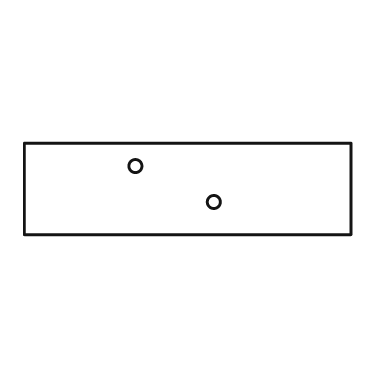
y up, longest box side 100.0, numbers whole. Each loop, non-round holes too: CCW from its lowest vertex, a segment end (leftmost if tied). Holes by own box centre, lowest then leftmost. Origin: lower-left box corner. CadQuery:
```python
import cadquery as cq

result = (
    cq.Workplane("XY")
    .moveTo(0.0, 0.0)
    .lineTo(100.0, 0.0)
    .lineTo(100.0, 28.0)
    .lineTo(0.0, 28.0)
    .close()
    .moveTo(58.0, 10.0)
    .circle(2.0)
    .moveTo(34.0, 21.0)
    .circle(2.0)
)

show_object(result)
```